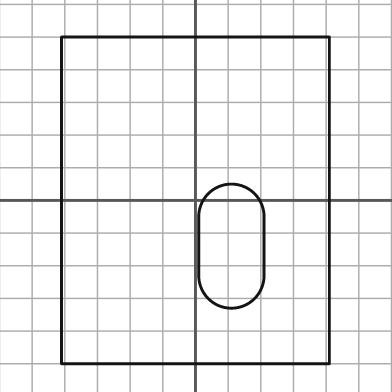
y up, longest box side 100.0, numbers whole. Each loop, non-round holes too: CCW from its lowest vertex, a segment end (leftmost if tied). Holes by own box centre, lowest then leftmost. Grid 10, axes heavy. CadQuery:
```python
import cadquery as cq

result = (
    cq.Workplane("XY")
    .moveTo(-41.0, -50.0)
    .lineTo(41.0, -50.0)
    .lineTo(41.0, 50.0)
    .lineTo(-41.0, 50.0)
    .close()
    .moveTo(1.0, -23.0)
    .threePointArc((11.0, -33.0), (21.0, -23.0))
    .lineTo(21.0, -5.0)
    .threePointArc((11.0, 5.0), (1.0, -5.0))
    .close()
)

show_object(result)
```